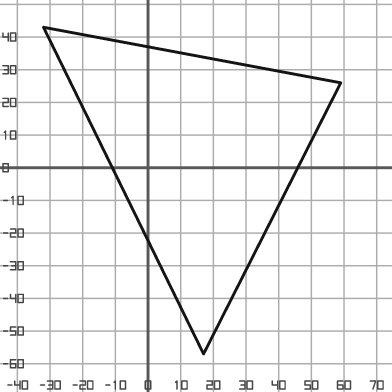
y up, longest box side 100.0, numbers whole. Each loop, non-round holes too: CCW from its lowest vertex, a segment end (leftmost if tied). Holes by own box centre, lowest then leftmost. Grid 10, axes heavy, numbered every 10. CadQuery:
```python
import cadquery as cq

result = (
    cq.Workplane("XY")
    .moveTo(17.0, -57.0)
    .lineTo(59.0, 26.0)
    .lineTo(-32.0, 43.0)
    .close()
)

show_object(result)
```